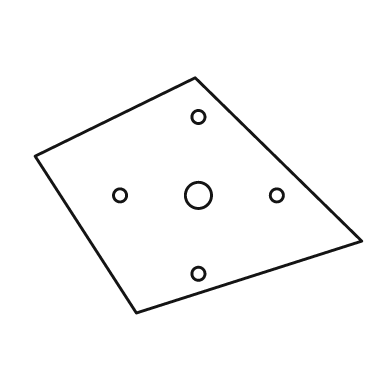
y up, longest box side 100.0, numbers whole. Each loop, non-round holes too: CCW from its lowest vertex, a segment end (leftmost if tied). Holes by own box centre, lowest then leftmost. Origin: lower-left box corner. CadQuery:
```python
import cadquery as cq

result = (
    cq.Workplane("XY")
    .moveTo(31.0, 0.0)
    .lineTo(100.0, 22.0)
    .lineTo(49.0, 72.0)
    .lineTo(0.0, 48.0)
    .close()
    .moveTo(50.0, 12.0)
    .circle(2.0)
    .moveTo(26.0, 36.0)
    .circle(2.0)
    .moveTo(50.0, 36.0)
    .circle(4.0)
    .moveTo(74.0, 36.0)
    .circle(2.0)
    .moveTo(50.0, 60.0)
    .circle(2.0)
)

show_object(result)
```